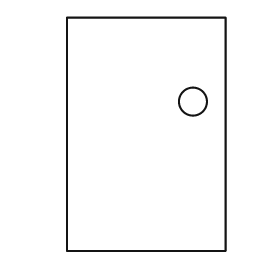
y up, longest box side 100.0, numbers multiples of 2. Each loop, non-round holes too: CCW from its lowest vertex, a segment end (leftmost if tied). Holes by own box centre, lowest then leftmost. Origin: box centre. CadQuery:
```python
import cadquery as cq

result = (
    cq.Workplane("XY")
    .moveTo(-34.0, -50.0)
    .lineTo(34.0, -50.0)
    .lineTo(34.0, 50.0)
    .lineTo(-34.0, 50.0)
    .close()
    .moveTo(20.0, 14.0)
    .circle(6.0)
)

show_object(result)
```